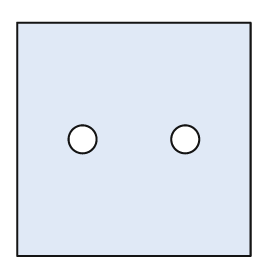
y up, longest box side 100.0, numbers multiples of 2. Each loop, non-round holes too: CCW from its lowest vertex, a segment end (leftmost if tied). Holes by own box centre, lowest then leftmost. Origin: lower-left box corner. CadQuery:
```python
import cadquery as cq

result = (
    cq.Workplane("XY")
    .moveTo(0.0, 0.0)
    .lineTo(100.0, 0.0)
    .lineTo(100.0, 100.0)
    .lineTo(0.0, 100.0)
    .close()
    .moveTo(28.0, 50.0)
    .circle(6.0)
    .moveTo(72.0, 50.0)
    .circle(6.0)
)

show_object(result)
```